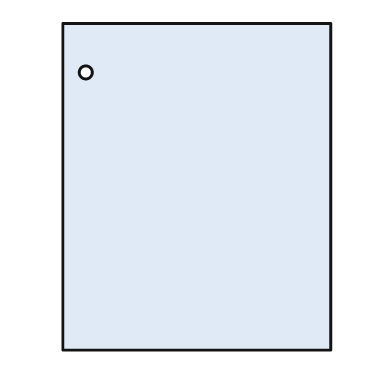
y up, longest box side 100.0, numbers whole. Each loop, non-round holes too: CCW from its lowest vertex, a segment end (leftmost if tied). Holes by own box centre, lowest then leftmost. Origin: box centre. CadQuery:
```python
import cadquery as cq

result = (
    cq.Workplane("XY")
    .moveTo(-41.0, -50.0)
    .lineTo(41.0, -50.0)
    .lineTo(41.0, 50.0)
    .lineTo(-41.0, 50.0)
    .close()
    .moveTo(-34.0, 35.0)
    .circle(2.0)
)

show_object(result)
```